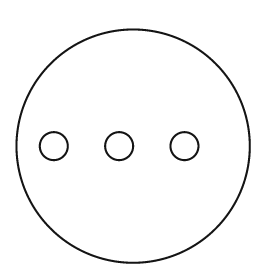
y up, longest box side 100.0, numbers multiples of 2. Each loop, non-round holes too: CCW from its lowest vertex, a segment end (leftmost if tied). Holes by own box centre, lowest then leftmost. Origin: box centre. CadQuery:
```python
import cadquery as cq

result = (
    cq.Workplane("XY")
    .moveTo(0.0, 0.0)
    .circle(50.0)
    .moveTo(-34.0, 0.0)
    .circle(6.0)
    .moveTo(-6.0, 0.0)
    .circle(6.0)
    .moveTo(22.0, 0.0)
    .circle(6.0)
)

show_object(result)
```